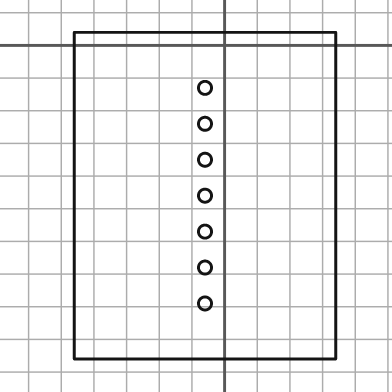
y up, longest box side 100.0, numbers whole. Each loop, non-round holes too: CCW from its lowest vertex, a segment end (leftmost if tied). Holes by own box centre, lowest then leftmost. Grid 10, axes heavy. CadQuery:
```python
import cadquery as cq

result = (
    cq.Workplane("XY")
    .moveTo(-46.0, -96.0)
    .lineTo(34.0, -96.0)
    .lineTo(34.0, 4.0)
    .lineTo(-46.0, 4.0)
    .close()
    .moveTo(-6.0, -79.0)
    .circle(2.0)
    .moveTo(-6.0, -68.0)
    .circle(2.0)
    .moveTo(-6.0, -57.0)
    .circle(2.0)
    .moveTo(-6.0, -46.0)
    .circle(2.0)
    .moveTo(-6.0, -35.0)
    .circle(2.0)
    .moveTo(-6.0, -24.0)
    .circle(2.0)
    .moveTo(-6.0, -13.0)
    .circle(2.0)
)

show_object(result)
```